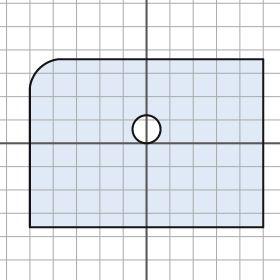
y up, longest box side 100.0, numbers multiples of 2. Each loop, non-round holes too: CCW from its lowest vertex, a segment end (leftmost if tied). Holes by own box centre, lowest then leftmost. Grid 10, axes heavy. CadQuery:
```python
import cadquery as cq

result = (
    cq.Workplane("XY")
    .moveTo(-50.0, -36.0)
    .lineTo(50.0, -36.0)
    .lineTo(50.0, 36.0)
    .lineTo(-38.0, 36.0)
    .threePointArc((-46.0, 32.0), (-50.0, 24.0))
    .close()
    .moveTo(0.0, 6.0)
    .circle(6.0)
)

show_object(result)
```